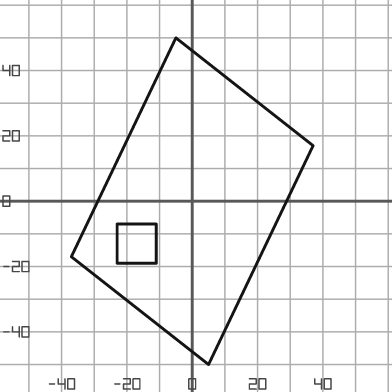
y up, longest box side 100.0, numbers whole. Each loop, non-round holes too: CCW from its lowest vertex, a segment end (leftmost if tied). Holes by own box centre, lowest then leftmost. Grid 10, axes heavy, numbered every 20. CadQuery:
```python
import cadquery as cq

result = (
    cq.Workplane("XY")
    .moveTo(5.0, -50.0)
    .lineTo(37.0, 17.0)
    .lineTo(-5.0, 50.0)
    .lineTo(-37.0, -17.0)
    .close()
    .moveTo(-23.0, -19.0)
    .lineTo(-11.0, -19.0)
    .lineTo(-11.0, -7.0)
    .lineTo(-23.0, -7.0)
    .close()
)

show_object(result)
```